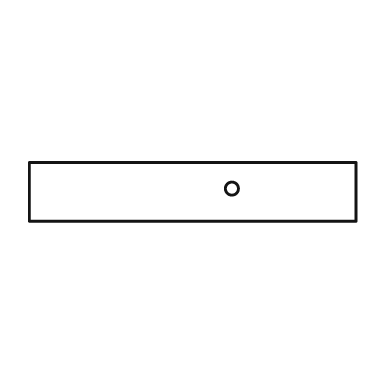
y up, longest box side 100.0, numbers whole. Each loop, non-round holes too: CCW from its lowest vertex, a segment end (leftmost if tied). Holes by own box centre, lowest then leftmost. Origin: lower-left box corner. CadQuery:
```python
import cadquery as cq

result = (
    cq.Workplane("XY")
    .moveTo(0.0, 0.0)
    .lineTo(100.0, 0.0)
    .lineTo(100.0, 18.0)
    .lineTo(0.0, 18.0)
    .close()
    .moveTo(62.0, 10.0)
    .circle(2.0)
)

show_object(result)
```